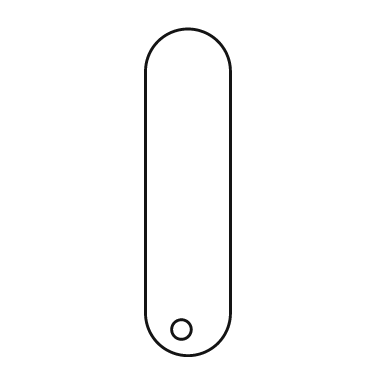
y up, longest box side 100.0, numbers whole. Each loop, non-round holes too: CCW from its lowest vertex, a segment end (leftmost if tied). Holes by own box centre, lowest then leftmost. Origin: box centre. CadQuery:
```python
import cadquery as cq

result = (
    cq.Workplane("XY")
    .moveTo(-13.0, -37.0)
    .threePointArc((0.0, -50.0), (13.0, -37.0))
    .lineTo(13.0, 37.0)
    .threePointArc((0.0, 50.0), (-13.0, 37.0))
    .close()
    .moveTo(-2.0, -42.0)
    .circle(3.0)
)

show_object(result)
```